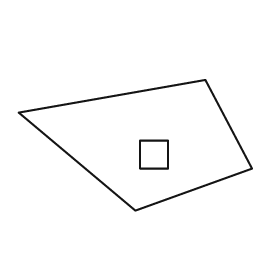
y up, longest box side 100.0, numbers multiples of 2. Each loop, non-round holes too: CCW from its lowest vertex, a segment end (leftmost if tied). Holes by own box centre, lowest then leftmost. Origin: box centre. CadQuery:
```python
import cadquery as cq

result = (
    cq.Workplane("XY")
    .moveTo(0.0, -28.0)
    .lineTo(50.0, -10.0)
    .lineTo(30.0, 28.0)
    .lineTo(-50.0, 14.0)
    .close()
    .moveTo(2.0, -10.0)
    .lineTo(14.0, -10.0)
    .lineTo(14.0, 2.0)
    .lineTo(2.0, 2.0)
    .close()
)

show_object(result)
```